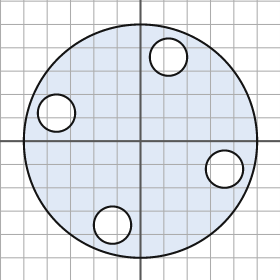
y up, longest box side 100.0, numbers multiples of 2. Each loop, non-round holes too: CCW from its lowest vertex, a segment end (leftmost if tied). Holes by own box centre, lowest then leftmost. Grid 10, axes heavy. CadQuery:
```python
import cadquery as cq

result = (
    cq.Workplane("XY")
    .moveTo(0.0, 0.0)
    .circle(50.0)
    .moveTo(-12.0, -36.0)
    .circle(8.0)
    .moveTo(36.0, -12.0)
    .circle(8.0)
    .moveTo(-36.0, 12.0)
    .circle(8.0)
    .moveTo(12.0, 36.0)
    .circle(8.0)
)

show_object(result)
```